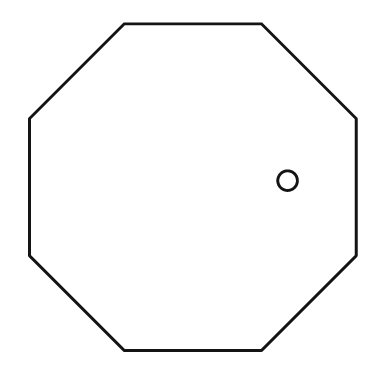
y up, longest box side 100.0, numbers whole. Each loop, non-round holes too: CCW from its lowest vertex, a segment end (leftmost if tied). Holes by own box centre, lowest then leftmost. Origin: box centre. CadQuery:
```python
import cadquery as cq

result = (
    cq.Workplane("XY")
    .moveTo(-21.0, -50.0)
    .lineTo(21.0, -50.0)
    .lineTo(50.0, -21.0)
    .lineTo(50.0, 21.0)
    .lineTo(21.0, 50.0)
    .lineTo(-21.0, 50.0)
    .lineTo(-50.0, 21.0)
    .lineTo(-50.0, -21.0)
    .close()
    .moveTo(29.0, 2.0)
    .circle(3.0)
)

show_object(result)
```